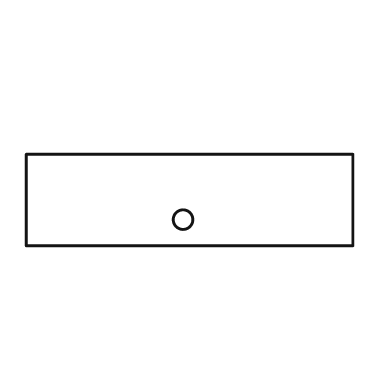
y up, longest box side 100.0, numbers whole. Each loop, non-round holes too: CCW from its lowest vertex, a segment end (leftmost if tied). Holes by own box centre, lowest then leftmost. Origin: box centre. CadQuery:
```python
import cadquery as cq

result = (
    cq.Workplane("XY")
    .moveTo(-50.0, -14.0)
    .lineTo(50.0, -14.0)
    .lineTo(50.0, 14.0)
    .lineTo(-50.0, 14.0)
    .close()
    .moveTo(-2.0, -6.0)
    .circle(3.0)
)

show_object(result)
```